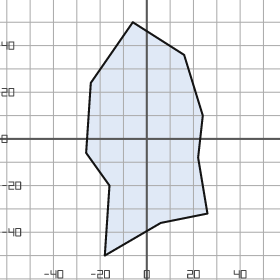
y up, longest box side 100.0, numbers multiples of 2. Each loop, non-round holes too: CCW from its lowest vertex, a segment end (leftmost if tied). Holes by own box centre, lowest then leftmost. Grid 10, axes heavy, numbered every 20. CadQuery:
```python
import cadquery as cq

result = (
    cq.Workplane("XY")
    .moveTo(-18.0, -50.0)
    .lineTo(6.0, -36.0)
    .lineTo(26.0, -32.0)
    .lineTo(22.0, -8.0)
    .lineTo(24.0, 10.0)
    .lineTo(16.0, 36.0)
    .lineTo(-6.0, 50.0)
    .lineTo(-24.0, 24.0)
    .lineTo(-26.0, -6.0)
    .lineTo(-16.0, -20.0)
    .close()
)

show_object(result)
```